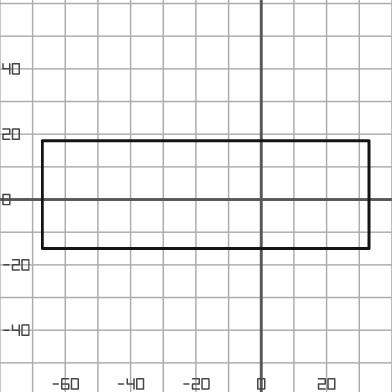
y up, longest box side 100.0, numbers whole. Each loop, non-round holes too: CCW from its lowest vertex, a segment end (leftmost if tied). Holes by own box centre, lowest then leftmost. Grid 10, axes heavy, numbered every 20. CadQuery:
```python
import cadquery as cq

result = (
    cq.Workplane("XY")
    .moveTo(-67.0, -15.0)
    .lineTo(33.0, -15.0)
    .lineTo(33.0, 18.0)
    .lineTo(-67.0, 18.0)
    .close()
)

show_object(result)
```